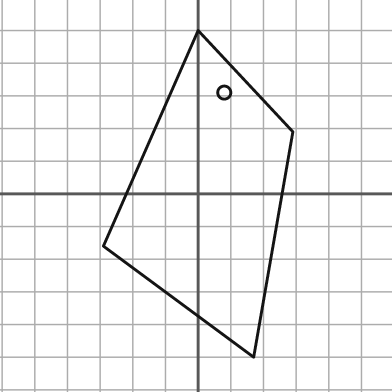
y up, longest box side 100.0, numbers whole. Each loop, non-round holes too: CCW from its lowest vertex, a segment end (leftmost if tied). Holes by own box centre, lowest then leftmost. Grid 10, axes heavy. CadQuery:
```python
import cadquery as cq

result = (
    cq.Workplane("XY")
    .moveTo(17.0, -50.0)
    .lineTo(29.0, 19.0)
    .lineTo(0.0, 50.0)
    .lineTo(-29.0, -16.0)
    .close()
    .moveTo(8.0, 31.0)
    .circle(2.0)
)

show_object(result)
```